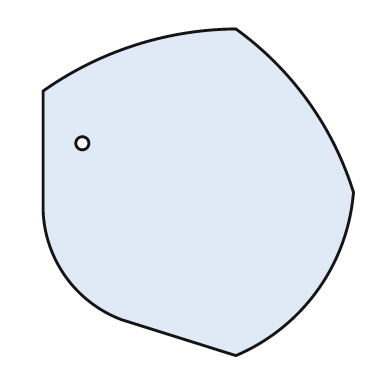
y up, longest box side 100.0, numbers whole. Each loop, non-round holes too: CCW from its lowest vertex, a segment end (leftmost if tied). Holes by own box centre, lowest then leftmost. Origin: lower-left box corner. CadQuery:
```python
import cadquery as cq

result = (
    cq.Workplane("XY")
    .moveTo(59.0, 0.0)
    .threePointArc((84.0, 20.0), (95.0, 50.0))
    .threePointArc((81.0, 78.0), (59.0, 100.0))
    .threePointArc((28.0, 95.0), (0.0, 81.0))
    .lineTo(0.0, 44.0)
    .threePointArc((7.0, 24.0), (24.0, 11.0))
    .close()
    .moveTo(12.0, 65.0)
    .circle(2.0)
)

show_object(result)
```